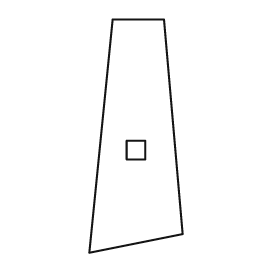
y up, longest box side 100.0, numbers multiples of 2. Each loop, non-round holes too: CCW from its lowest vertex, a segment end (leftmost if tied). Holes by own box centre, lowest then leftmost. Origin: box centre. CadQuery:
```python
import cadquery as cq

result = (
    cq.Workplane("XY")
    .moveTo(-20.0, -50.0)
    .lineTo(20.0, -42.0)
    .lineTo(12.0, 50.0)
    .lineTo(-10.0, 50.0)
    .close()
    .moveTo(-4.0, -10.0)
    .lineTo(4.0, -10.0)
    .lineTo(4.0, -2.0)
    .lineTo(-4.0, -2.0)
    .close()
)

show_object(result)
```